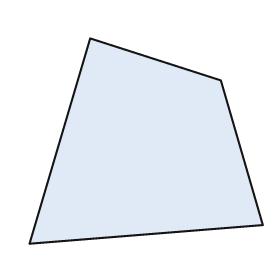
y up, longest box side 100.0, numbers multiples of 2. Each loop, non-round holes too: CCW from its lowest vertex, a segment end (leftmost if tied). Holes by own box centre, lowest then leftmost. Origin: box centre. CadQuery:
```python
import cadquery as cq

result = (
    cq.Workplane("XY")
    .moveTo(-50.0, -44.0)
    .lineTo(50.0, -36.0)
    .lineTo(32.0, 26.0)
    .lineTo(-24.0, 44.0)
    .close()
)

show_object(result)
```